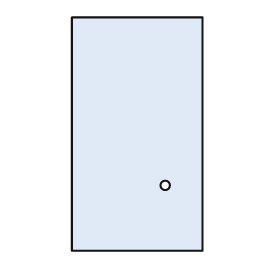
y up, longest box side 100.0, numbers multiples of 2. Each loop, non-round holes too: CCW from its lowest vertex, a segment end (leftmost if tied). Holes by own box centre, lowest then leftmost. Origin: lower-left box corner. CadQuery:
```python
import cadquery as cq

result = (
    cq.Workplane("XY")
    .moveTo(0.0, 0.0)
    .lineTo(56.0, 0.0)
    .lineTo(56.0, 100.0)
    .lineTo(0.0, 100.0)
    .close()
    .moveTo(40.0, 28.0)
    .circle(2.0)
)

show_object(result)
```